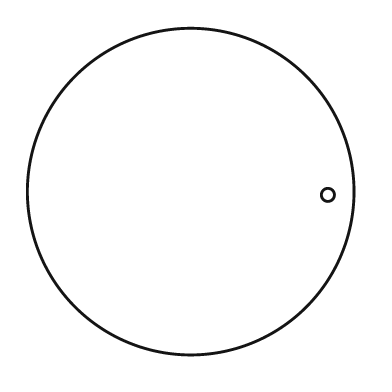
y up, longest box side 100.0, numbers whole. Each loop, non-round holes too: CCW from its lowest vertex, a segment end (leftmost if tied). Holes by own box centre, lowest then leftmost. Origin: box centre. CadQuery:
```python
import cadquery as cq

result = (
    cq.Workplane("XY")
    .moveTo(0.0, 0.0)
    .circle(50.0)
    .moveTo(42.0, -1.0)
    .circle(2.0)
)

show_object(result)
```